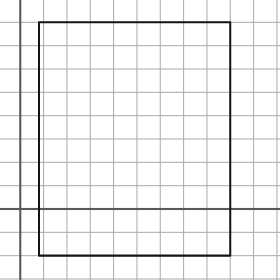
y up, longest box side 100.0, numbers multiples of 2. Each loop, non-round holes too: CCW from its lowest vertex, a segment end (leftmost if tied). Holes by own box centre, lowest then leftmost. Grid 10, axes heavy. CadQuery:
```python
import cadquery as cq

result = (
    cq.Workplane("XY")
    .moveTo(8.0, -20.0)
    .lineTo(90.0, -20.0)
    .lineTo(90.0, 80.0)
    .lineTo(8.0, 80.0)
    .close()
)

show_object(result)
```